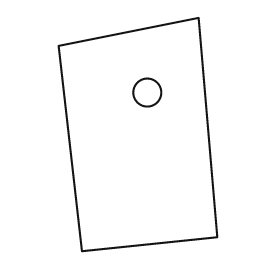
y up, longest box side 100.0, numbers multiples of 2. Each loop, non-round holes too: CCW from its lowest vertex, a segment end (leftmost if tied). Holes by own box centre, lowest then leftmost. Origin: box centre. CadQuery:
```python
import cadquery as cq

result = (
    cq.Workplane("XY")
    .moveTo(-24.0, -50.0)
    .lineTo(34.0, -44.0)
    .lineTo(26.0, 50.0)
    .lineTo(-34.0, 38.0)
    .close()
    .moveTo(4.0, 18.0)
    .circle(6.0)
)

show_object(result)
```